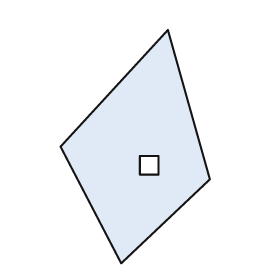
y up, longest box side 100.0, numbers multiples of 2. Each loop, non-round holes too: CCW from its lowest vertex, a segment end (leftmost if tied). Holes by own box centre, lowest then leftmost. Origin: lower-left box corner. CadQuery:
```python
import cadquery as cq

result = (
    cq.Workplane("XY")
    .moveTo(26.0, 0.0)
    .lineTo(64.0, 36.0)
    .lineTo(46.0, 100.0)
    .lineTo(0.0, 50.0)
    .close()
    .moveTo(34.0, 38.0)
    .lineTo(42.0, 38.0)
    .lineTo(42.0, 46.0)
    .lineTo(34.0, 46.0)
    .close()
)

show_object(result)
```